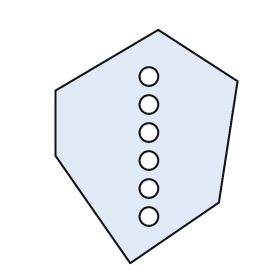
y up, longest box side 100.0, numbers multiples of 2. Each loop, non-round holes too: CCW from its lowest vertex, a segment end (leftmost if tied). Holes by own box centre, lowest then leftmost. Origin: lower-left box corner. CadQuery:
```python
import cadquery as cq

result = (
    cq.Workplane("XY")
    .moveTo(32.0, 0.0)
    .lineTo(70.0, 26.0)
    .lineTo(78.0, 78.0)
    .lineTo(44.0, 100.0)
    .lineTo(0.0, 74.0)
    .lineTo(0.0, 46.0)
    .close()
    .moveTo(40.0, 20.0)
    .circle(4.0)
    .moveTo(40.0, 32.0)
    .circle(4.0)
    .moveTo(40.0, 44.0)
    .circle(4.0)
    .moveTo(40.0, 56.0)
    .circle(4.0)
    .moveTo(40.0, 68.0)
    .circle(4.0)
    .moveTo(40.0, 80.0)
    .circle(4.0)
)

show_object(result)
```